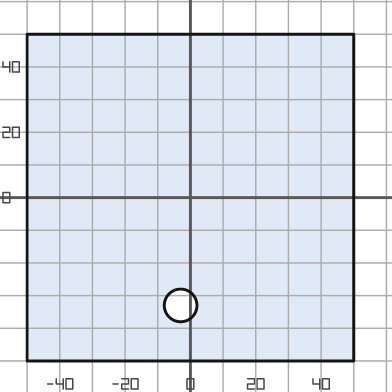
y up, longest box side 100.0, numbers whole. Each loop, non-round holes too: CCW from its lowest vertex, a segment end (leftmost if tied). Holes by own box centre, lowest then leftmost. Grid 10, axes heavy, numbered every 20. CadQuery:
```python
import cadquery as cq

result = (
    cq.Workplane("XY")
    .moveTo(-50.0, -50.0)
    .lineTo(50.0, -50.0)
    .lineTo(50.0, 50.0)
    .lineTo(-50.0, 50.0)
    .close()
    .moveTo(-3.0, -33.0)
    .circle(5.0)
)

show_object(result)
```